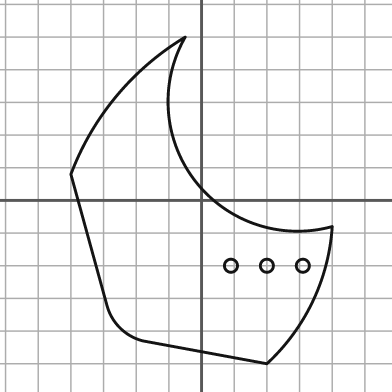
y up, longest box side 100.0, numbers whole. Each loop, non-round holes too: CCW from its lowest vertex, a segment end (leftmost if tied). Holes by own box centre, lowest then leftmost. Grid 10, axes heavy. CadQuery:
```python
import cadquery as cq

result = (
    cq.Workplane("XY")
    .moveTo(20.0, -50.0)
    .threePointArc((34.0, -31.0), (40.0, -8.0))
    .threePointArc((-2.0, 6.0), (-5.0, 50.0))
    .threePointArc((-26.0, 32.0), (-40.0, 8.0))
    .lineTo(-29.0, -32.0)
    .threePointArc((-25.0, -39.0), (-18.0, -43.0))
    .close()
    .moveTo(9.0, -20.0)
    .circle(2.0)
    .moveTo(20.0, -20.0)
    .circle(2.0)
    .moveTo(31.0, -20.0)
    .circle(2.0)
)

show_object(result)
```